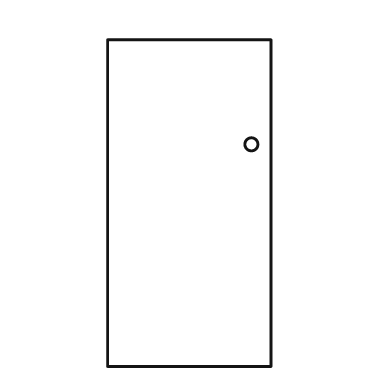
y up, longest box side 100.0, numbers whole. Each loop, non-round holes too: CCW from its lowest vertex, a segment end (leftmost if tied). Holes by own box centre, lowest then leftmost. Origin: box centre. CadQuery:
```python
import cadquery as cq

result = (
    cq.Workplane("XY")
    .moveTo(-25.0, -50.0)
    .lineTo(25.0, -50.0)
    .lineTo(25.0, 50.0)
    .lineTo(-25.0, 50.0)
    .close()
    .moveTo(19.0, 18.0)
    .circle(2.0)
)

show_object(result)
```